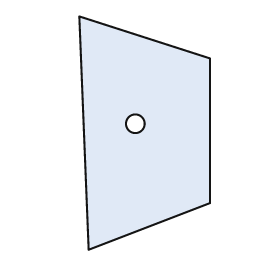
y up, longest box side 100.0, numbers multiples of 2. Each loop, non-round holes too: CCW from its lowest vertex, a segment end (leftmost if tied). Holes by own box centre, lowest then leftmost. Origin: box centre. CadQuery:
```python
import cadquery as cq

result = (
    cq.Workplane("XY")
    .moveTo(-24.0, -50.0)
    .lineTo(28.0, -30.0)
    .lineTo(28.0, 32.0)
    .lineTo(-28.0, 50.0)
    .close()
    .moveTo(-4.0, 4.0)
    .circle(4.0)
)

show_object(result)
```